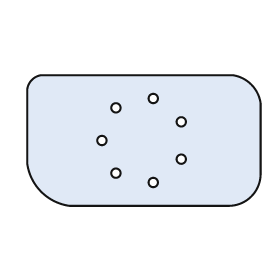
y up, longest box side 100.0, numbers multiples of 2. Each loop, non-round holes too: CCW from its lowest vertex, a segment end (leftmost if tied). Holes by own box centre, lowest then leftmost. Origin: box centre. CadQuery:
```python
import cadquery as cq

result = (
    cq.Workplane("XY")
    .moveTo(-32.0, -28.0)
    .lineTo(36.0, -28.0)
    .threePointArc((46.0, -24.0), (50.0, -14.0))
    .lineTo(50.0, 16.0)
    .threePointArc((46.0, 24.0), (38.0, 28.0))
    .lineTo(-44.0, 28.0)
    .threePointArc((-48.0, 26.0), (-50.0, 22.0))
    .lineTo(-50.0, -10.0)
    .threePointArc((-44.0, -22.0), (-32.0, -28.0))
    .close()
    .moveTo(4.0, -18.0)
    .circle(2.0)
    .moveTo(-12.0, -14.0)
    .circle(2.0)
    .moveTo(16.0, -8.0)
    .circle(2.0)
    .moveTo(-18.0, 0.0)
    .circle(2.0)
    .moveTo(16.0, 8.0)
    .circle(2.0)
    .moveTo(-12.0, 14.0)
    .circle(2.0)
    .moveTo(4.0, 18.0)
    .circle(2.0)
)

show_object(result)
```